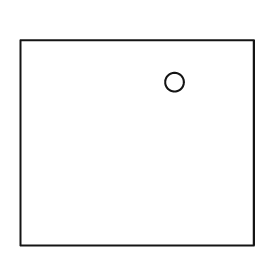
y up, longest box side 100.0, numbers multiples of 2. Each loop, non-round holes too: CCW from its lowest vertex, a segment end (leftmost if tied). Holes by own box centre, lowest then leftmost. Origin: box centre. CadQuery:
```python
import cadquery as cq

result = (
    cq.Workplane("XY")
    .moveTo(-50.0, -44.0)
    .lineTo(50.0, -44.0)
    .lineTo(50.0, 44.0)
    .lineTo(-50.0, 44.0)
    .close()
    .moveTo(16.0, 26.0)
    .circle(4.0)
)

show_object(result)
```